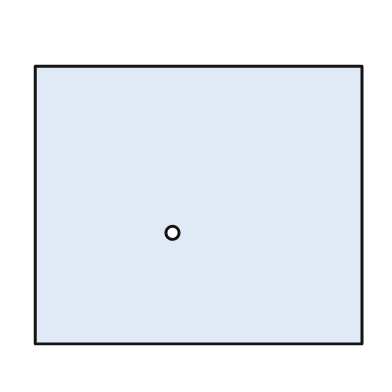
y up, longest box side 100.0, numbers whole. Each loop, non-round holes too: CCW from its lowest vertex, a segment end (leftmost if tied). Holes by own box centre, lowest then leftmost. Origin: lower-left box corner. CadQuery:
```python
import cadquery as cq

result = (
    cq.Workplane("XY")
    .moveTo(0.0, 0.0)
    .lineTo(100.0, 0.0)
    .lineTo(100.0, 85.0)
    .lineTo(0.0, 85.0)
    .close()
    .moveTo(42.0, 34.0)
    .circle(2.0)
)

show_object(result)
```